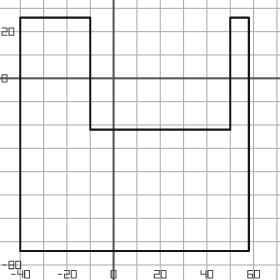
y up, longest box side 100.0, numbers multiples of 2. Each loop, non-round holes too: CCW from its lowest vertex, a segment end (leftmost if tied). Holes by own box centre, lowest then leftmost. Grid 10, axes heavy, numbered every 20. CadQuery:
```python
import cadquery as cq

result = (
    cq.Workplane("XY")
    .moveTo(-40.0, -74.0)
    .lineTo(58.0, -74.0)
    .lineTo(58.0, 26.0)
    .lineTo(50.0, 26.0)
    .lineTo(50.0, -22.0)
    .lineTo(-10.0, -22.0)
    .lineTo(-10.0, 26.0)
    .lineTo(-40.0, 26.0)
    .close()
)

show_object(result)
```